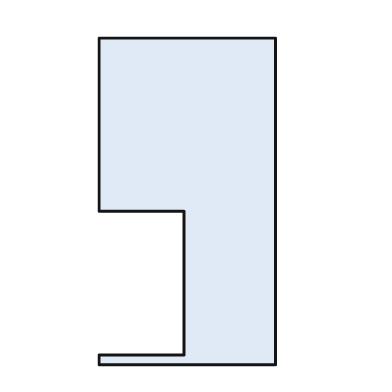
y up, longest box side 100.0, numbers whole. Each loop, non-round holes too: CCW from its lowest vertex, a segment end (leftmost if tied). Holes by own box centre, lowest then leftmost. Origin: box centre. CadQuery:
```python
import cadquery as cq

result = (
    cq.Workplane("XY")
    .moveTo(-27.0, -50.0)
    .lineTo(27.0, -50.0)
    .lineTo(27.0, 50.0)
    .lineTo(-27.0, 50.0)
    .lineTo(-27.0, -3.0)
    .lineTo(-1.0, -3.0)
    .lineTo(-1.0, -47.0)
    .lineTo(-27.0, -47.0)
    .close()
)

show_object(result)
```